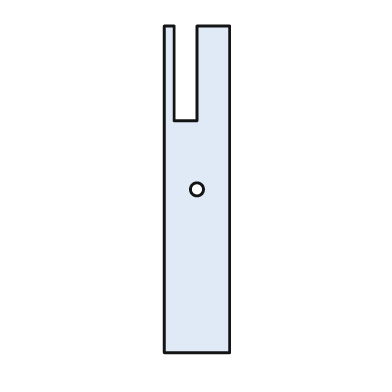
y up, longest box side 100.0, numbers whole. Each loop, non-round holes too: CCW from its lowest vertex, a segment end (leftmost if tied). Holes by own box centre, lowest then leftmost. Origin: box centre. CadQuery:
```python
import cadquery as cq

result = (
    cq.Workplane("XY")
    .moveTo(-10.0, -50.0)
    .lineTo(10.0, -50.0)
    .lineTo(10.0, 50.0)
    .lineTo(0.0, 50.0)
    .lineTo(0.0, 21.0)
    .lineTo(-7.0, 21.0)
    .lineTo(-7.0, 50.0)
    .lineTo(-10.0, 50.0)
    .close()
    .moveTo(0.0, 0.0)
    .circle(2.0)
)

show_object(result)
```